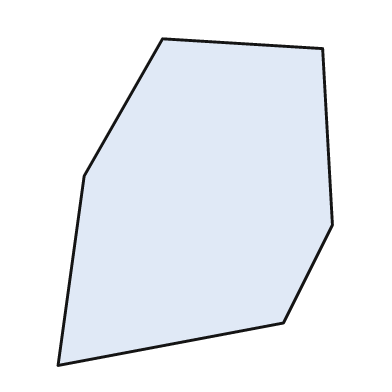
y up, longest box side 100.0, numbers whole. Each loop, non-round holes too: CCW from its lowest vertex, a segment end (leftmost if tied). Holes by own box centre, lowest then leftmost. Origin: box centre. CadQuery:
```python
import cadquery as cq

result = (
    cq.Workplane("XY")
    .moveTo(-42.0, -50.0)
    .lineTo(27.0, -37.0)
    .lineTo(42.0, -7.0)
    .lineTo(39.0, 47.0)
    .lineTo(-10.0, 50.0)
    .lineTo(-34.0, 8.0)
    .close()
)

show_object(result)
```